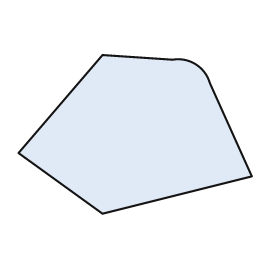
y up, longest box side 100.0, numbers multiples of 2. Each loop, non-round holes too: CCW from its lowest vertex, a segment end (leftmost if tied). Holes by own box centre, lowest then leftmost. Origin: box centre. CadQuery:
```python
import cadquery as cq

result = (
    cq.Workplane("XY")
    .moveTo(-14.0, -34.0)
    .lineTo(50.0, -18.0)
    .lineTo(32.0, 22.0)
    .threePointArc((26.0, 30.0), (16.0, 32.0))
    .lineTo(-14.0, 34.0)
    .lineTo(-50.0, -8.0)
    .close()
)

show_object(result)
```